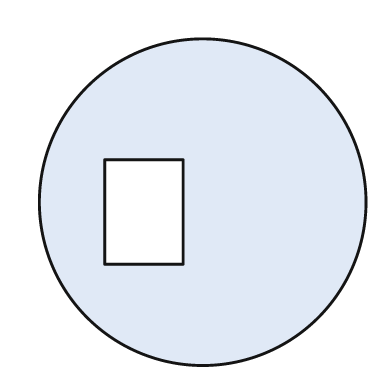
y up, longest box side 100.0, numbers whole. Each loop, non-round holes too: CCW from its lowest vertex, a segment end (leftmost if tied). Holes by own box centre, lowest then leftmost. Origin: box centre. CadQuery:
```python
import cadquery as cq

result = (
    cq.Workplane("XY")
    .moveTo(0.0, 0.0)
    .circle(50.0)
    .moveTo(-30.0, -19.0)
    .lineTo(-6.0, -19.0)
    .lineTo(-6.0, 13.0)
    .lineTo(-30.0, 13.0)
    .close()
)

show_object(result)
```